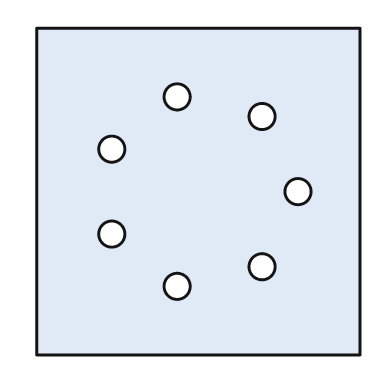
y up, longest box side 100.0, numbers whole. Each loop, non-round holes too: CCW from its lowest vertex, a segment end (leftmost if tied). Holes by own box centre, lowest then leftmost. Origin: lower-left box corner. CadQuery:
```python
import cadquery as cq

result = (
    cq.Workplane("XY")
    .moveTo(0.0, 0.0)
    .lineTo(99.0, 0.0)
    .lineTo(99.0, 100.0)
    .lineTo(0.0, 100.0)
    .close()
    .moveTo(43.0, 21.0)
    .circle(4.0)
    .moveTo(69.0, 27.0)
    .circle(4.0)
    .moveTo(23.0, 37.0)
    .circle(4.0)
    .moveTo(80.0, 50.0)
    .circle(4.0)
    .moveTo(23.0, 63.0)
    .circle(4.0)
    .moveTo(69.0, 73.0)
    .circle(4.0)
    .moveTo(43.0, 79.0)
    .circle(4.0)
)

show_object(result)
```